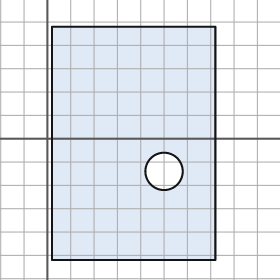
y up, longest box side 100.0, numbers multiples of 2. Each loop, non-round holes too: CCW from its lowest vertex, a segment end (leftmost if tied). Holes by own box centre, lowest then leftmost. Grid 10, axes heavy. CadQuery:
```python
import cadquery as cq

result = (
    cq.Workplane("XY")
    .moveTo(2.0, -52.0)
    .lineTo(72.0, -52.0)
    .lineTo(72.0, 48.0)
    .lineTo(2.0, 48.0)
    .close()
    .moveTo(50.0, -14.0)
    .circle(8.0)
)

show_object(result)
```